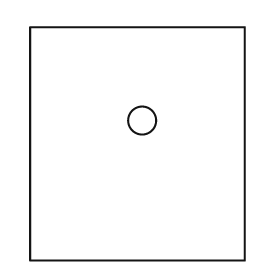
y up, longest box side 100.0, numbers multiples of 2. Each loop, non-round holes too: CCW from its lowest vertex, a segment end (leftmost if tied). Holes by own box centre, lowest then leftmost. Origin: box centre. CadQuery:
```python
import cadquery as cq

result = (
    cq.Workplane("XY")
    .moveTo(-46.0, -50.0)
    .lineTo(46.0, -50.0)
    .lineTo(46.0, 50.0)
    .lineTo(-46.0, 50.0)
    .close()
    .moveTo(2.0, 10.0)
    .circle(6.0)
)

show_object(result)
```